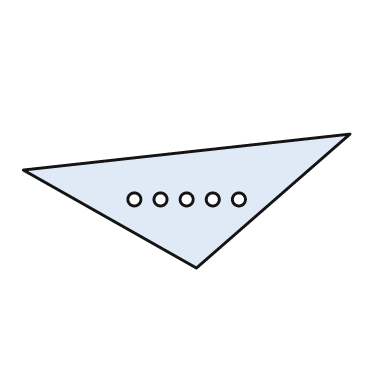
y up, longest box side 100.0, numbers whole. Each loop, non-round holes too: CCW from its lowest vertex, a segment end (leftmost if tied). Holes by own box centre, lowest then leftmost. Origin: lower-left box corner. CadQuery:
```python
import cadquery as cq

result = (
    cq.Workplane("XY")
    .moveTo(53.0, 0.0)
    .lineTo(100.0, 41.0)
    .lineTo(0.0, 30.0)
    .close()
    .moveTo(34.0, 21.0)
    .circle(2.0)
    .moveTo(42.0, 21.0)
    .circle(2.0)
    .moveTo(50.0, 21.0)
    .circle(2.0)
    .moveTo(58.0, 21.0)
    .circle(2.0)
    .moveTo(66.0, 21.0)
    .circle(2.0)
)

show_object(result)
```